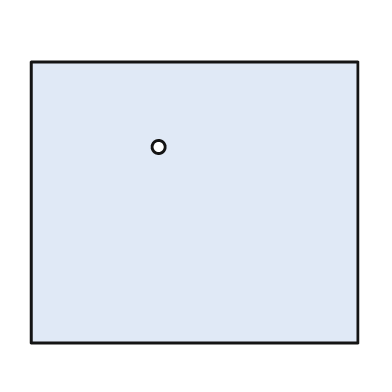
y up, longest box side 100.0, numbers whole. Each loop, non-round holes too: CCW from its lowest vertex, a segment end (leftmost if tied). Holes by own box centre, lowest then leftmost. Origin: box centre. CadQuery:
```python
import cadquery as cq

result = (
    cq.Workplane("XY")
    .moveTo(-50.0, -43.0)
    .lineTo(50.0, -43.0)
    .lineTo(50.0, 43.0)
    .lineTo(-50.0, 43.0)
    .close()
    .moveTo(-11.0, 17.0)
    .circle(2.0)
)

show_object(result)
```